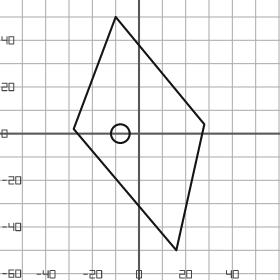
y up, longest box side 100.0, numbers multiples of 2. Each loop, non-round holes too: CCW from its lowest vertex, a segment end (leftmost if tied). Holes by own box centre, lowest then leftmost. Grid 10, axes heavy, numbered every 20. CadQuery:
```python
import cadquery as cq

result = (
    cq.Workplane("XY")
    .moveTo(16.0, -50.0)
    .lineTo(28.0, 4.0)
    .lineTo(-10.0, 50.0)
    .lineTo(-28.0, 2.0)
    .close()
    .moveTo(-8.0, 0.0)
    .circle(4.0)
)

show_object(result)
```